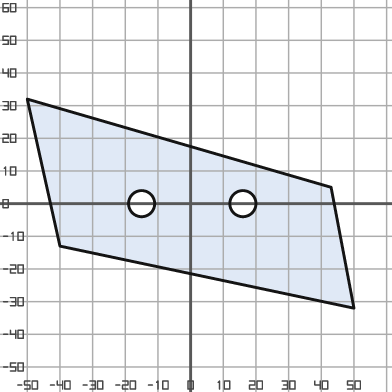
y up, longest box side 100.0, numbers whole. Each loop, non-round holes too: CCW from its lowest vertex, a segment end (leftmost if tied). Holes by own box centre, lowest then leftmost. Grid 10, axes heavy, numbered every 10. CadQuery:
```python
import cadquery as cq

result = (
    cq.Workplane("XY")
    .moveTo(50.0, -32.0)
    .lineTo(43.0, 5.0)
    .lineTo(-50.0, 32.0)
    .lineTo(-40.0, -13.0)
    .close()
    .moveTo(-15.0, 0.0)
    .circle(4.0)
    .moveTo(16.0, 0.0)
    .circle(4.0)
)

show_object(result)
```